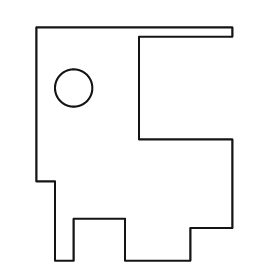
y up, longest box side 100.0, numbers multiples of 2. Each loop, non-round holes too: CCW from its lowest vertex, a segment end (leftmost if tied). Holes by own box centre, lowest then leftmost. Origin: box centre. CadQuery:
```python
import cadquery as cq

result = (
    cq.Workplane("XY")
    .moveTo(-34.0, -50.0)
    .lineTo(-26.0, -50.0)
    .lineTo(-26.0, -32.0)
    .lineTo(-4.0, -32.0)
    .lineTo(-4.0, -50.0)
    .lineTo(24.0, -50.0)
    .lineTo(24.0, -36.0)
    .lineTo(42.0, -36.0)
    .lineTo(42.0, 2.0)
    .lineTo(2.0, 2.0)
    .lineTo(2.0, 46.0)
    .lineTo(42.0, 46.0)
    .lineTo(42.0, 50.0)
    .lineTo(-42.0, 50.0)
    .lineTo(-42.0, -16.0)
    .lineTo(-34.0, -16.0)
    .close()
    .moveTo(-26.0, 24.0)
    .circle(8.0)
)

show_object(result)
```